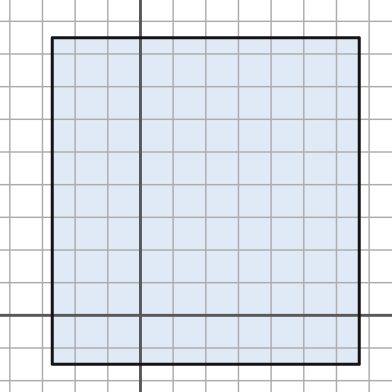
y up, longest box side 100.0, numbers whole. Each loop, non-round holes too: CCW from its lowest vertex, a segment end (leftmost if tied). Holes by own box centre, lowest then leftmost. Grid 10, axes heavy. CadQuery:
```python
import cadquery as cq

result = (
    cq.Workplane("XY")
    .moveTo(-27.0, -15.0)
    .lineTo(67.0, -15.0)
    .lineTo(67.0, 85.0)
    .lineTo(-27.0, 85.0)
    .close()
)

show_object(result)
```